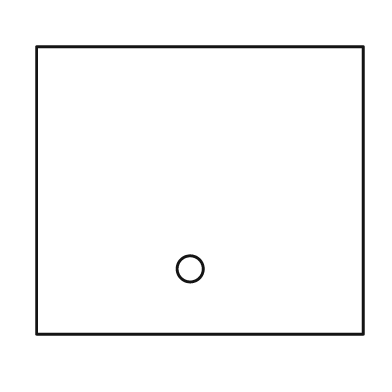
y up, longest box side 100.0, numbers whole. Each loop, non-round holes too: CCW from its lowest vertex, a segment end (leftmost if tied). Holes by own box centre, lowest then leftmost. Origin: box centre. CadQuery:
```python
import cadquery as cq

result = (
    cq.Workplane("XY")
    .moveTo(-50.0, -44.0)
    .lineTo(50.0, -44.0)
    .lineTo(50.0, 44.0)
    .lineTo(-50.0, 44.0)
    .close()
    .moveTo(-3.0, -24.0)
    .circle(4.0)
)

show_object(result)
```